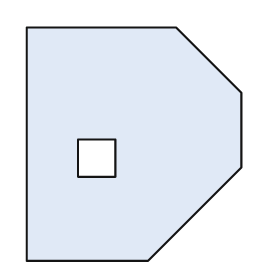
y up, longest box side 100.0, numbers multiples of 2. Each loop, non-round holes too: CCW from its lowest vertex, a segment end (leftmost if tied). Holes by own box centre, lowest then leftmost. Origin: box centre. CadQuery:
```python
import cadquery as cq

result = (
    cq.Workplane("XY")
    .moveTo(-46.0, -50.0)
    .lineTo(6.0, -50.0)
    .lineTo(46.0, -10.0)
    .lineTo(46.0, 22.0)
    .lineTo(18.0, 50.0)
    .lineTo(-46.0, 50.0)
    .close()
    .moveTo(-24.0, -14.0)
    .lineTo(-8.0, -14.0)
    .lineTo(-8.0, 2.0)
    .lineTo(-24.0, 2.0)
    .close()
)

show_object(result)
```